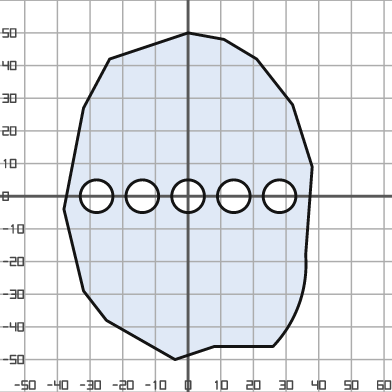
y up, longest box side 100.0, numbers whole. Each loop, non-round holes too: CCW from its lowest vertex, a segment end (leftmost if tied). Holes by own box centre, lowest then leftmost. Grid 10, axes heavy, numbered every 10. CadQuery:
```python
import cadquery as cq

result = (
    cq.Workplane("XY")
    .moveTo(-4.0, -50.0)
    .lineTo(8.0, -46.0)
    .lineTo(26.0, -46.0)
    .threePointArc((34.0, -33.0), (36.0, -18.0))
    .lineTo(38.0, 9.0)
    .lineTo(32.0, 28.0)
    .lineTo(21.0, 42.0)
    .lineTo(11.0, 48.0)
    .lineTo(0.0, 50.0)
    .lineTo(-24.0, 42.0)
    .lineTo(-32.0, 27.0)
    .lineTo(-38.0, -4.0)
    .lineTo(-32.0, -29.0)
    .lineTo(-25.0, -38.0)
    .close()
    .moveTo(-28.0, 0.0)
    .circle(5.0)
    .moveTo(-14.0, 0.0)
    .circle(5.0)
    .moveTo(0.0, 0.0)
    .circle(5.0)
    .moveTo(14.0, 0.0)
    .circle(5.0)
    .moveTo(28.0, 0.0)
    .circle(5.0)
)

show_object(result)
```